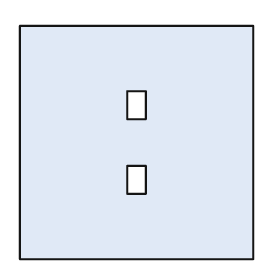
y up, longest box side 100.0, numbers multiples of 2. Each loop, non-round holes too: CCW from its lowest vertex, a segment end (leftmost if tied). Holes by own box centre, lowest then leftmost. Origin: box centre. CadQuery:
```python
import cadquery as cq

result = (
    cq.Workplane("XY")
    .moveTo(-50.0, -50.0)
    .lineTo(50.0, -50.0)
    .lineTo(50.0, 50.0)
    .lineTo(-50.0, 50.0)
    .close()
    .moveTo(-4.0, -22.0)
    .lineTo(4.0, -22.0)
    .lineTo(4.0, -10.0)
    .lineTo(-4.0, -10.0)
    .close()
    .moveTo(-4.0, 10.0)
    .lineTo(4.0, 10.0)
    .lineTo(4.0, 22.0)
    .lineTo(-4.0, 22.0)
    .close()
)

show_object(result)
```